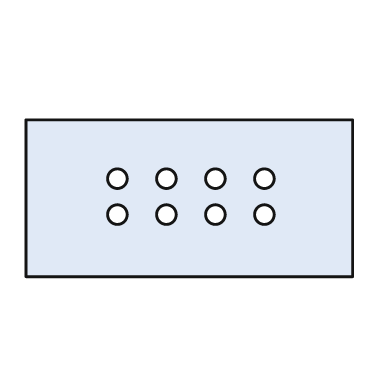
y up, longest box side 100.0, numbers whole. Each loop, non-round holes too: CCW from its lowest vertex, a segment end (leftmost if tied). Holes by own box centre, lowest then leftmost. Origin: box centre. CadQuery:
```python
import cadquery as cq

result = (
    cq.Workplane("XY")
    .moveTo(-50.0, -24.0)
    .lineTo(50.0, -24.0)
    .lineTo(50.0, 24.0)
    .lineTo(-50.0, 24.0)
    .close()
    .moveTo(-22.0, -5.0)
    .circle(3.0)
    .moveTo(-7.0, -5.0)
    .circle(3.0)
    .moveTo(8.0, -5.0)
    .circle(3.0)
    .moveTo(23.0, -5.0)
    .circle(3.0)
    .moveTo(-22.0, 6.0)
    .circle(3.0)
    .moveTo(-7.0, 6.0)
    .circle(3.0)
    .moveTo(8.0, 6.0)
    .circle(3.0)
    .moveTo(23.0, 6.0)
    .circle(3.0)
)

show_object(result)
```